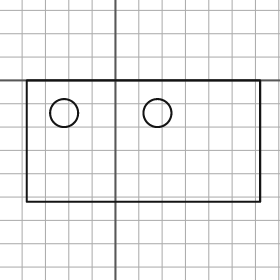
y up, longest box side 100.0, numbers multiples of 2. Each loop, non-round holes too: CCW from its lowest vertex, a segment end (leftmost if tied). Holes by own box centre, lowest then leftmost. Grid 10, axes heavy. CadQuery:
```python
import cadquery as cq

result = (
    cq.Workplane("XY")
    .moveTo(-38.0, -52.0)
    .lineTo(62.0, -52.0)
    .lineTo(62.0, 0.0)
    .lineTo(-38.0, 0.0)
    .close()
    .moveTo(-22.0, -14.0)
    .circle(6.0)
    .moveTo(18.0, -14.0)
    .circle(6.0)
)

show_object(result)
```